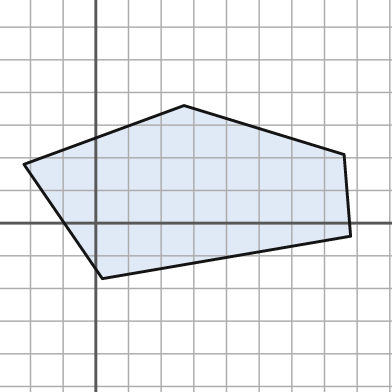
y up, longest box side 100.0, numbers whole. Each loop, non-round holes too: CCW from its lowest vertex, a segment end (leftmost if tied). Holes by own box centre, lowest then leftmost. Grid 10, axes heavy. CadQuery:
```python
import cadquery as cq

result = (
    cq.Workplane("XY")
    .moveTo(2.0, -17.0)
    .lineTo(78.0, -4.0)
    .lineTo(76.0, 21.0)
    .lineTo(27.0, 36.0)
    .lineTo(-22.0, 18.0)
    .close()
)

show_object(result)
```